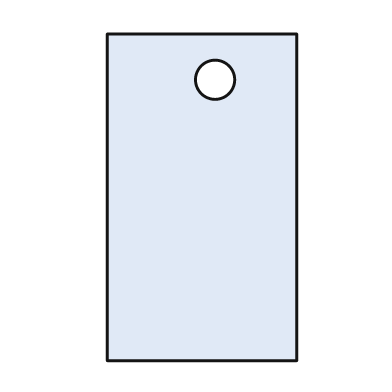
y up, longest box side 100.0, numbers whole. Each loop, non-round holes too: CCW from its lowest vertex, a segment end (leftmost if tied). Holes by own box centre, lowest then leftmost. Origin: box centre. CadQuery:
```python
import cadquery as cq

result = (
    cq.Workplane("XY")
    .moveTo(-29.0, -50.0)
    .lineTo(29.0, -50.0)
    .lineTo(29.0, 50.0)
    .lineTo(-29.0, 50.0)
    .close()
    .moveTo(4.0, 36.0)
    .circle(6.0)
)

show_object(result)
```